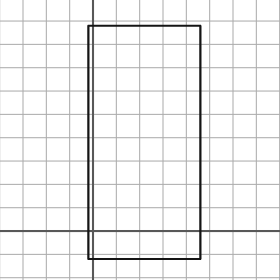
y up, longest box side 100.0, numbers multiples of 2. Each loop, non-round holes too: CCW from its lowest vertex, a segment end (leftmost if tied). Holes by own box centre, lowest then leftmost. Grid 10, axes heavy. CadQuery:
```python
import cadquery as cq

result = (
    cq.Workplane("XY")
    .moveTo(-2.0, -12.0)
    .lineTo(46.0, -12.0)
    .lineTo(46.0, 88.0)
    .lineTo(-2.0, 88.0)
    .close()
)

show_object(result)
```